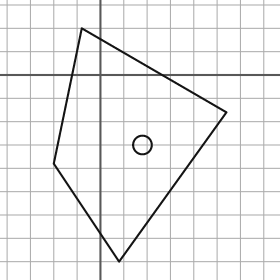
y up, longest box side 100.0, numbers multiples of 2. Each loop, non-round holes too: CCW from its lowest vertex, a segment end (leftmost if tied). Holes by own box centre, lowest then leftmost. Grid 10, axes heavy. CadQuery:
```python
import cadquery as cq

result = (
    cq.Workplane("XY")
    .moveTo(8.0, -80.0)
    .lineTo(54.0, -16.0)
    .lineTo(-8.0, 20.0)
    .lineTo(-20.0, -38.0)
    .close()
    .moveTo(18.0, -30.0)
    .circle(4.0)
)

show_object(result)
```